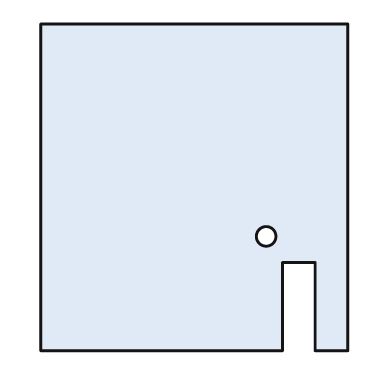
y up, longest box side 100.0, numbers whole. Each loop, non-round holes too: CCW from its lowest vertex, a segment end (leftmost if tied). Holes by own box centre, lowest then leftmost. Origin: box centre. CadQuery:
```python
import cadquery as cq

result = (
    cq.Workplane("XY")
    .moveTo(-47.0, -50.0)
    .lineTo(27.0, -50.0)
    .lineTo(27.0, -23.0)
    .lineTo(37.0, -23.0)
    .lineTo(37.0, -50.0)
    .lineTo(47.0, -50.0)
    .lineTo(47.0, 50.0)
    .lineTo(-47.0, 50.0)
    .close()
    .moveTo(22.0, -15.0)
    .circle(3.0)
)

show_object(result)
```